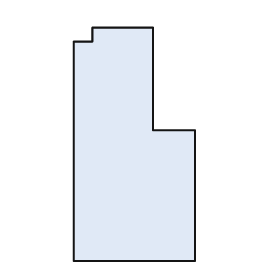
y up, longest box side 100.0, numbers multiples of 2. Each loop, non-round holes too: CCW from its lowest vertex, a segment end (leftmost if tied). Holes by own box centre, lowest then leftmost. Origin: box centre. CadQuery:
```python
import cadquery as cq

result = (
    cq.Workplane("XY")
    .moveTo(-26.0, -50.0)
    .lineTo(26.0, -50.0)
    .lineTo(26.0, 6.0)
    .lineTo(8.0, 6.0)
    .lineTo(8.0, 50.0)
    .lineTo(-18.0, 50.0)
    .lineTo(-18.0, 44.0)
    .lineTo(-26.0, 44.0)
    .close()
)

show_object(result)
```